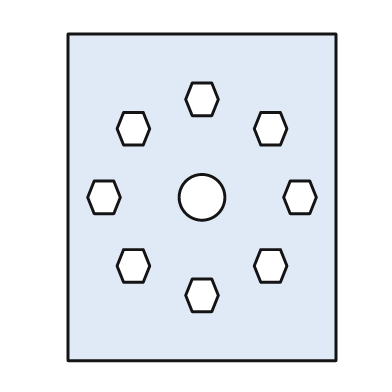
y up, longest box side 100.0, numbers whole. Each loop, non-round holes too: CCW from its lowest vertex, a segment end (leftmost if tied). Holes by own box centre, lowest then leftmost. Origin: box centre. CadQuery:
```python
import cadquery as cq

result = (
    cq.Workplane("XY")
    .moveTo(-41.0, -50.0)
    .lineTo(41.0, -50.0)
    .lineTo(41.0, 50.0)
    .lineTo(-41.0, 50.0)
    .close()
    .moveTo(-3.0, -35.0)
    .lineTo(3.0, -35.0)
    .lineTo(5.0, -30.0)
    .lineTo(3.0, -25.0)
    .lineTo(-3.0, -25.0)
    .lineTo(-5.0, -30.0)
    .close()
    .moveTo(-24.0, -26.0)
    .lineTo(-18.0, -26.0)
    .lineTo(-16.0, -21.0)
    .lineTo(-18.0, -16.0)
    .lineTo(-24.0, -16.0)
    .lineTo(-26.0, -21.0)
    .close()
    .moveTo(18.0, -26.0)
    .lineTo(24.0, -26.0)
    .lineTo(26.0, -21.0)
    .lineTo(24.0, -16.0)
    .lineTo(18.0, -16.0)
    .lineTo(16.0, -21.0)
    .close()
    .moveTo(-33.0, -5.0)
    .lineTo(-27.0, -5.0)
    .lineTo(-25.0, 0.0)
    .lineTo(-27.0, 5.0)
    .lineTo(-33.0, 5.0)
    .lineTo(-35.0, 0.0)
    .close()
    .moveTo(0.0, 0.0)
    .circle(7.0)
    .moveTo(27.0, -5.0)
    .lineTo(33.0, -5.0)
    .lineTo(35.0, 0.0)
    .lineTo(33.0, 5.0)
    .lineTo(27.0, 5.0)
    .lineTo(25.0, 0.0)
    .close()
    .moveTo(-24.0, 16.0)
    .lineTo(-18.0, 16.0)
    .lineTo(-16.0, 21.0)
    .lineTo(-18.0, 26.0)
    .lineTo(-24.0, 26.0)
    .lineTo(-26.0, 21.0)
    .close()
    .moveTo(18.0, 16.0)
    .lineTo(24.0, 16.0)
    .lineTo(26.0, 21.0)
    .lineTo(24.0, 26.0)
    .lineTo(18.0, 26.0)
    .lineTo(16.0, 21.0)
    .close()
    .moveTo(-3.0, 25.0)
    .lineTo(3.0, 25.0)
    .lineTo(5.0, 30.0)
    .lineTo(3.0, 35.0)
    .lineTo(-3.0, 35.0)
    .lineTo(-5.0, 30.0)
    .close()
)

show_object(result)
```